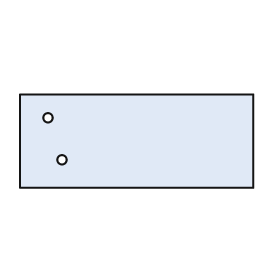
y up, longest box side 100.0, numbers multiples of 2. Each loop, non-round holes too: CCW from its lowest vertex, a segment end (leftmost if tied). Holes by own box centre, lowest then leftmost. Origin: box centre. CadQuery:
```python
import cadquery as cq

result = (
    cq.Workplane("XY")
    .moveTo(-50.0, -20.0)
    .lineTo(50.0, -20.0)
    .lineTo(50.0, 20.0)
    .lineTo(-50.0, 20.0)
    .close()
    .moveTo(-32.0, -8.0)
    .circle(2.0)
    .moveTo(-38.0, 10.0)
    .circle(2.0)
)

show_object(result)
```